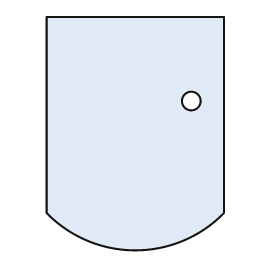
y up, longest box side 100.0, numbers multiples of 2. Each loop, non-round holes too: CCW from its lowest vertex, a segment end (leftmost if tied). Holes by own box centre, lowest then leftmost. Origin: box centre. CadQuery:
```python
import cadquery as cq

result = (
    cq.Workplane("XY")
    .moveTo(-38.0, -34.0)
    .threePointArc((0.0, -50.0), (38.0, -34.0))
    .lineTo(38.0, 50.0)
    .lineTo(-38.0, 50.0)
    .close()
    .moveTo(24.0, 14.0)
    .circle(4.0)
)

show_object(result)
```